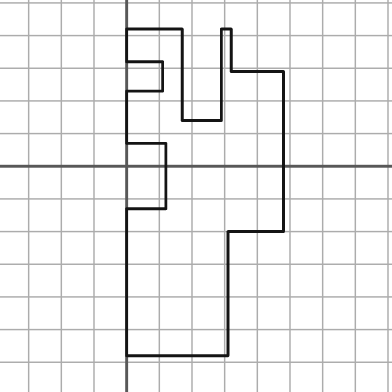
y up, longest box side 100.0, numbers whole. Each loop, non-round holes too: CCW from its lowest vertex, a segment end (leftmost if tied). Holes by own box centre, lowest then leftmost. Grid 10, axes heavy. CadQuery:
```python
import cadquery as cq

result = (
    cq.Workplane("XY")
    .moveTo(0.0, -58.0)
    .lineTo(31.0, -58.0)
    .lineTo(31.0, -20.0)
    .lineTo(48.0, -20.0)
    .lineTo(48.0, 29.0)
    .lineTo(32.0, 29.0)
    .lineTo(32.0, 42.0)
    .lineTo(29.0, 42.0)
    .lineTo(29.0, 14.0)
    .lineTo(17.0, 14.0)
    .lineTo(17.0, 42.0)
    .lineTo(0.0, 42.0)
    .lineTo(0.0, 32.0)
    .lineTo(11.0, 32.0)
    .lineTo(11.0, 23.0)
    .lineTo(0.0, 23.0)
    .lineTo(0.0, 7.0)
    .lineTo(12.0, 7.0)
    .lineTo(12.0, -13.0)
    .lineTo(0.0, -13.0)
    .close()
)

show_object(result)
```